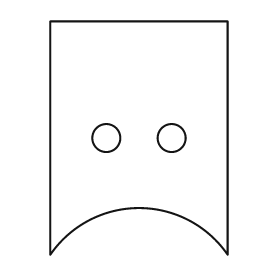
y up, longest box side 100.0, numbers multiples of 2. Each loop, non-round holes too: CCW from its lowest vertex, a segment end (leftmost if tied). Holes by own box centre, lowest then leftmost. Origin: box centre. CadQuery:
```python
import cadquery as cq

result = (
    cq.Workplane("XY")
    .moveTo(-38.0, -50.0)
    .threePointArc((0.0, -30.0), (38.0, -50.0))
    .lineTo(38.0, 50.0)
    .lineTo(-38.0, 50.0)
    .close()
    .moveTo(-14.0, 0.0)
    .circle(6.0)
    .moveTo(14.0, 0.0)
    .circle(6.0)
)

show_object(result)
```